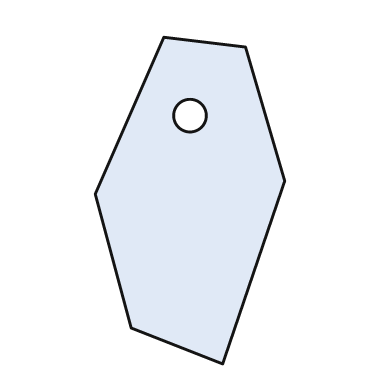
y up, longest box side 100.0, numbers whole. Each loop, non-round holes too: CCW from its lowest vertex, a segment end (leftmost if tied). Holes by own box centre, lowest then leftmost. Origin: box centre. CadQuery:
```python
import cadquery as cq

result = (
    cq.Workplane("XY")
    .moveTo(10.0, -50.0)
    .lineTo(29.0, 6.0)
    .lineTo(17.0, 47.0)
    .lineTo(-8.0, 50.0)
    .lineTo(-29.0, 2.0)
    .lineTo(-18.0, -39.0)
    .close()
    .moveTo(0.0, 26.0)
    .circle(5.0)
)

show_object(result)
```